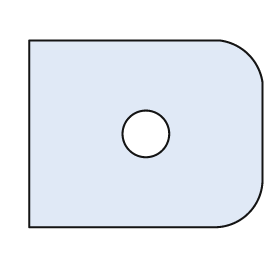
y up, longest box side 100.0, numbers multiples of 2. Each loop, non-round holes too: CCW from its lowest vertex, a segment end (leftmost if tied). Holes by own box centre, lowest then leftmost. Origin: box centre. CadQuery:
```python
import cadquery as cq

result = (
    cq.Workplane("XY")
    .moveTo(-50.0, -40.0)
    .lineTo(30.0, -40.0)
    .threePointArc((44.0, -34.0), (50.0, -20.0))
    .lineTo(50.0, 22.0)
    .threePointArc((44.0, 34.0), (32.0, 40.0))
    .lineTo(-50.0, 40.0)
    .close()
    .moveTo(0.0, 0.0)
    .circle(10.0)
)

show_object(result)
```